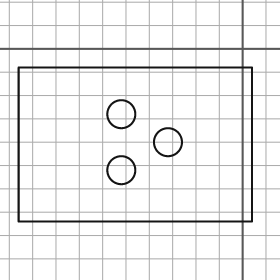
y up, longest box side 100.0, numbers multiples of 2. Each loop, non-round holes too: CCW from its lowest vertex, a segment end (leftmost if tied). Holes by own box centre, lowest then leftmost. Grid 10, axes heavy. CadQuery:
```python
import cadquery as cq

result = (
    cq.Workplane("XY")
    .moveTo(-96.0, -74.0)
    .lineTo(4.0, -74.0)
    .lineTo(4.0, -8.0)
    .lineTo(-96.0, -8.0)
    .close()
    .moveTo(-52.0, -52.0)
    .circle(6.0)
    .moveTo(-32.0, -40.0)
    .circle(6.0)
    .moveTo(-52.0, -28.0)
    .circle(6.0)
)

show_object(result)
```